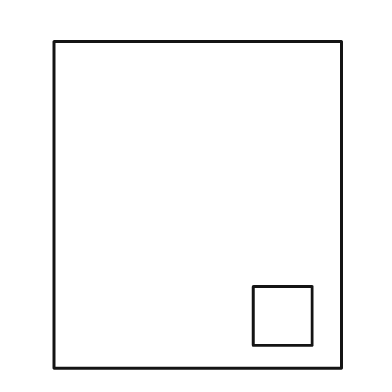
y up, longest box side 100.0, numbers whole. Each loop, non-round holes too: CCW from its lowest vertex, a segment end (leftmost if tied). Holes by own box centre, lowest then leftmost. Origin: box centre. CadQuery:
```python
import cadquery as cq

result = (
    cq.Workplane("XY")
    .moveTo(-44.0, -50.0)
    .lineTo(44.0, -50.0)
    .lineTo(44.0, 50.0)
    .lineTo(-44.0, 50.0)
    .close()
    .moveTo(17.0, -43.0)
    .lineTo(35.0, -43.0)
    .lineTo(35.0, -25.0)
    .lineTo(17.0, -25.0)
    .close()
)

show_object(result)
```